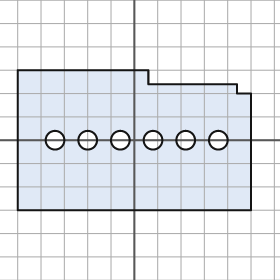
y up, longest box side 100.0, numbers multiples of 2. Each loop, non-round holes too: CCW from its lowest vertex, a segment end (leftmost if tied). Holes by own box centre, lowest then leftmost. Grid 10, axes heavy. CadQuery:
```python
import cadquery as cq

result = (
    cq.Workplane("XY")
    .moveTo(-50.0, -30.0)
    .lineTo(50.0, -30.0)
    .lineTo(50.0, 20.0)
    .lineTo(44.0, 20.0)
    .lineTo(44.0, 24.0)
    .lineTo(6.0, 24.0)
    .lineTo(6.0, 30.0)
    .lineTo(-50.0, 30.0)
    .close()
    .moveTo(-34.0, 0.0)
    .circle(4.0)
    .moveTo(-20.0, 0.0)
    .circle(4.0)
    .moveTo(-6.0, 0.0)
    .circle(4.0)
    .moveTo(8.0, 0.0)
    .circle(4.0)
    .moveTo(22.0, 0.0)
    .circle(4.0)
    .moveTo(36.0, 0.0)
    .circle(4.0)
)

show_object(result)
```